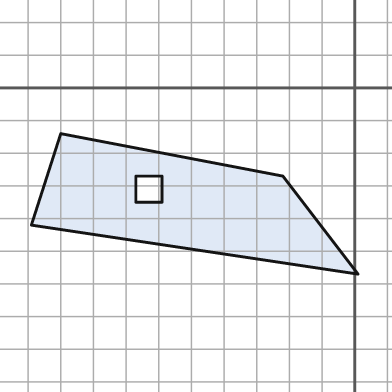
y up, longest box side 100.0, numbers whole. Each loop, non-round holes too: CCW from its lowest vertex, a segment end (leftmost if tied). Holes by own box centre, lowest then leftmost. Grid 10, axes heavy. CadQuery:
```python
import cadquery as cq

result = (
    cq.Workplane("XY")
    .moveTo(1.0, -57.0)
    .lineTo(-22.0, -27.0)
    .lineTo(-90.0, -14.0)
    .lineTo(-99.0, -42.0)
    .close()
    .moveTo(-67.0, -35.0)
    .lineTo(-59.0, -35.0)
    .lineTo(-59.0, -27.0)
    .lineTo(-67.0, -27.0)
    .close()
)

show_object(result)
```